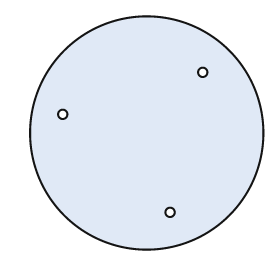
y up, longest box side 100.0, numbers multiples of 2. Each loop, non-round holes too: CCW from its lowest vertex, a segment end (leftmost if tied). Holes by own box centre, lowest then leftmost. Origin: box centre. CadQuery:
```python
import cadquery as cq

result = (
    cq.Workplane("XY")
    .moveTo(0.0, 0.0)
    .circle(50.0)
    .moveTo(10.0, -34.0)
    .circle(2.0)
    .moveTo(-36.0, 8.0)
    .circle(2.0)
    .moveTo(24.0, 26.0)
    .circle(2.0)
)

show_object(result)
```